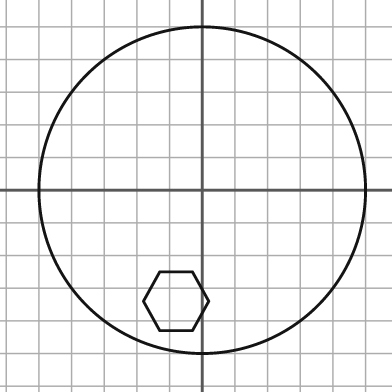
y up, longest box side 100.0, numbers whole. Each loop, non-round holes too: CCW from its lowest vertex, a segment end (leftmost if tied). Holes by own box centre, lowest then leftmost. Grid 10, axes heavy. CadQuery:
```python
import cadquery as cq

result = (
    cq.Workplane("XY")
    .moveTo(0.0, 0.0)
    .circle(50.0)
    .moveTo(-13.0, -43.0)
    .lineTo(-3.0, -43.0)
    .lineTo(2.0, -34.0)
    .lineTo(-3.0, -25.0)
    .lineTo(-13.0, -25.0)
    .lineTo(-18.0, -34.0)
    .close()
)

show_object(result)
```